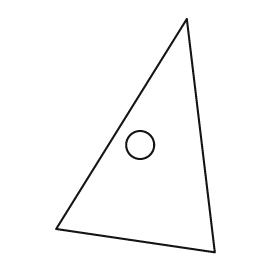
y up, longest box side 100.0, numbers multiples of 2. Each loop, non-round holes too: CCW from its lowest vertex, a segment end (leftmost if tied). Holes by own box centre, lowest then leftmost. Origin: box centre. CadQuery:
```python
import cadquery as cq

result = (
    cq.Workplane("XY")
    .moveTo(34.0, -50.0)
    .lineTo(22.0, 50.0)
    .lineTo(-34.0, -40.0)
    .close()
    .moveTo(2.0, -4.0)
    .circle(6.0)
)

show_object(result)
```